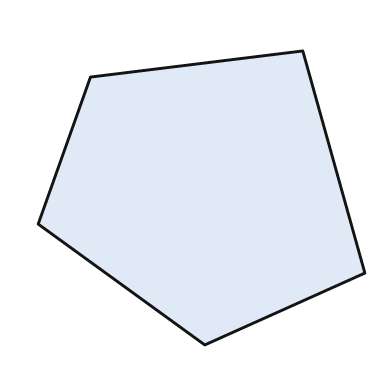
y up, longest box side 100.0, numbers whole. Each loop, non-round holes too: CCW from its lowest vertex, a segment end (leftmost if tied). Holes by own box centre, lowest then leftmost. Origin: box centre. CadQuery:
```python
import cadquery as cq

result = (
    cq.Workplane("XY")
    .moveTo(1.0, -45.0)
    .lineTo(50.0, -23.0)
    .lineTo(31.0, 45.0)
    .lineTo(-34.0, 37.0)
    .lineTo(-50.0, -8.0)
    .close()
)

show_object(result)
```